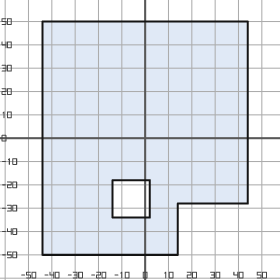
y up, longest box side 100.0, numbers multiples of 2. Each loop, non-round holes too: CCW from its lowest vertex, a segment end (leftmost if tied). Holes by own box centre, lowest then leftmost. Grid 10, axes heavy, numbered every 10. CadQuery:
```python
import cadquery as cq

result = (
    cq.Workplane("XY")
    .moveTo(-44.0, -50.0)
    .lineTo(14.0, -50.0)
    .lineTo(14.0, -28.0)
    .lineTo(44.0, -28.0)
    .lineTo(44.0, 50.0)
    .lineTo(-44.0, 50.0)
    .close()
    .moveTo(-14.0, -34.0)
    .lineTo(2.0, -34.0)
    .lineTo(2.0, -18.0)
    .lineTo(-14.0, -18.0)
    .close()
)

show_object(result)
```